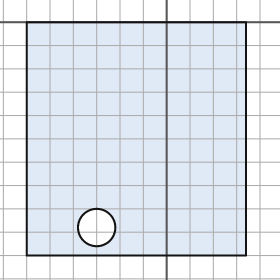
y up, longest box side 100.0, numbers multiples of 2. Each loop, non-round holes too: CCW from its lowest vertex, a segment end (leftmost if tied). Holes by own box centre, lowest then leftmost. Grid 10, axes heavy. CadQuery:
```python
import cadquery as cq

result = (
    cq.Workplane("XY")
    .moveTo(-60.0, -100.0)
    .lineTo(34.0, -100.0)
    .lineTo(34.0, 0.0)
    .lineTo(-60.0, 0.0)
    .close()
    .moveTo(-30.0, -88.0)
    .circle(8.0)
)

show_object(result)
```